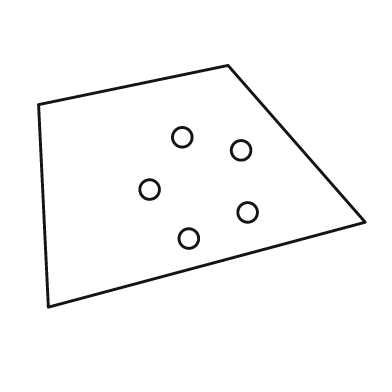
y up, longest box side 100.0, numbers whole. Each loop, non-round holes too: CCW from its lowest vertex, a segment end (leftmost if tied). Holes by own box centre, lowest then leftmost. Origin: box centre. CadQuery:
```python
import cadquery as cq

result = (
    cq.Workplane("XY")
    .moveTo(-47.0, -37.0)
    .lineTo(50.0, -11.0)
    .lineTo(8.0, 37.0)
    .lineTo(-50.0, 25.0)
    .close()
    .moveTo(-4.0, -16.0)
    .circle(3.0)
    .moveTo(14.0, -8.0)
    .circle(3.0)
    .moveTo(-16.0, -1.0)
    .circle(3.0)
    .moveTo(12.0, 11.0)
    .circle(3.0)
    .moveTo(-6.0, 15.0)
    .circle(3.0)
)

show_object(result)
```